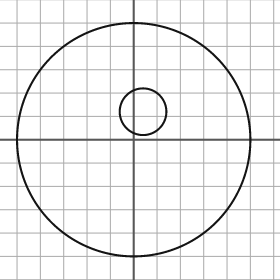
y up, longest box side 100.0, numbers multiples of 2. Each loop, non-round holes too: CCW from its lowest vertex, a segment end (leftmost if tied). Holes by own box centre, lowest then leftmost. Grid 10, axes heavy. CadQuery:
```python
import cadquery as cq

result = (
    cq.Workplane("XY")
    .moveTo(0.0, 0.0)
    .circle(50.0)
    .moveTo(4.0, 12.0)
    .circle(10.0)
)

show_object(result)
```